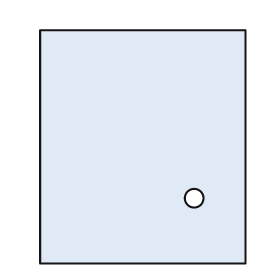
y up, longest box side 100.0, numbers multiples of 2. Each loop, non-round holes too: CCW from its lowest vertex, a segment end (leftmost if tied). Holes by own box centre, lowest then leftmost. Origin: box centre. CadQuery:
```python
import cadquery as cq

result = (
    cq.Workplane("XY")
    .moveTo(-44.0, -50.0)
    .lineTo(44.0, -50.0)
    .lineTo(44.0, 50.0)
    .lineTo(-44.0, 50.0)
    .close()
    .moveTo(22.0, -22.0)
    .circle(4.0)
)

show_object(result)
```